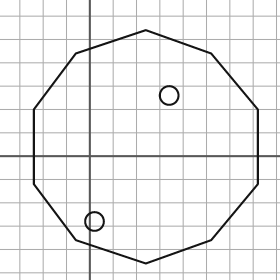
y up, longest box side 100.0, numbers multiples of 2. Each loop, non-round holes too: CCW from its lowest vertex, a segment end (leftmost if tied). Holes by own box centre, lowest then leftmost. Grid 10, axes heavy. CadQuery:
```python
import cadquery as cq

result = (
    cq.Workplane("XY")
    .moveTo(24.0, -46.0)
    .lineTo(52.0, -36.0)
    .lineTo(72.0, -12.0)
    .lineTo(72.0, 20.0)
    .lineTo(52.0, 44.0)
    .lineTo(24.0, 54.0)
    .lineTo(-6.0, 44.0)
    .lineTo(-24.0, 20.0)
    .lineTo(-24.0, -12.0)
    .lineTo(-6.0, -36.0)
    .close()
    .moveTo(2.0, -28.0)
    .circle(4.0)
    .moveTo(34.0, 26.0)
    .circle(4.0)
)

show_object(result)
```